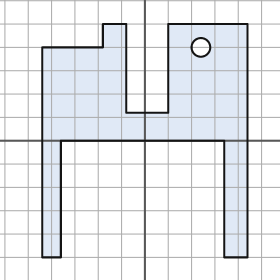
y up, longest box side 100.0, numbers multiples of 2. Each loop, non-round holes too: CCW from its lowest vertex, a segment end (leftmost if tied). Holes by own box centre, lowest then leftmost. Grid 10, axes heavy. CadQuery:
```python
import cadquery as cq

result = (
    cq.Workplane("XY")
    .moveTo(-44.0, -50.0)
    .lineTo(-36.0, -50.0)
    .lineTo(-36.0, 0.0)
    .lineTo(34.0, 0.0)
    .lineTo(34.0, -50.0)
    .lineTo(44.0, -50.0)
    .lineTo(44.0, 50.0)
    .lineTo(10.0, 50.0)
    .lineTo(10.0, 12.0)
    .lineTo(-8.0, 12.0)
    .lineTo(-8.0, 50.0)
    .lineTo(-18.0, 50.0)
    .lineTo(-18.0, 40.0)
    .lineTo(-44.0, 40.0)
    .close()
    .moveTo(24.0, 40.0)
    .circle(4.0)
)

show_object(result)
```